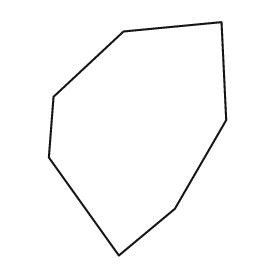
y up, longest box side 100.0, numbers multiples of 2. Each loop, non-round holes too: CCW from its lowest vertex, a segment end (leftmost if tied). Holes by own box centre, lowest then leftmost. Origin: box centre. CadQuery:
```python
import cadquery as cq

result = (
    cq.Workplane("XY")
    .moveTo(-8.0, -50.0)
    .lineTo(16.0, -30.0)
    .lineTo(38.0, 8.0)
    .lineTo(36.0, 50.0)
    .lineTo(-6.0, 46.0)
    .lineTo(-36.0, 18.0)
    .lineTo(-38.0, -8.0)
    .close()
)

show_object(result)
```